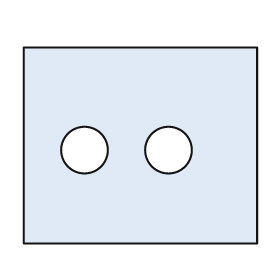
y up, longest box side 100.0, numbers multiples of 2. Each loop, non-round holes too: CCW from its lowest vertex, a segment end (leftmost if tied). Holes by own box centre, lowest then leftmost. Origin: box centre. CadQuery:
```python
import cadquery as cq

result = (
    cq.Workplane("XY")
    .moveTo(-50.0, -42.0)
    .lineTo(50.0, -42.0)
    .lineTo(50.0, 42.0)
    .lineTo(-50.0, 42.0)
    .close()
    .moveTo(-24.0, -2.0)
    .circle(10.0)
    .moveTo(12.0, -2.0)
    .circle(10.0)
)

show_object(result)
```